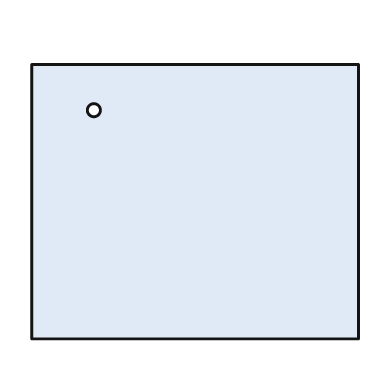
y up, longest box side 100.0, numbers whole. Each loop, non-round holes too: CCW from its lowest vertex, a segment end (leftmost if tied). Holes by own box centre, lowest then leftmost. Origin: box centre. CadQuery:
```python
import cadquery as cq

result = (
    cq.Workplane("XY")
    .moveTo(-50.0, -42.0)
    .lineTo(50.0, -42.0)
    .lineTo(50.0, 42.0)
    .lineTo(-50.0, 42.0)
    .close()
    .moveTo(-31.0, 28.0)
    .circle(2.0)
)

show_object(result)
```